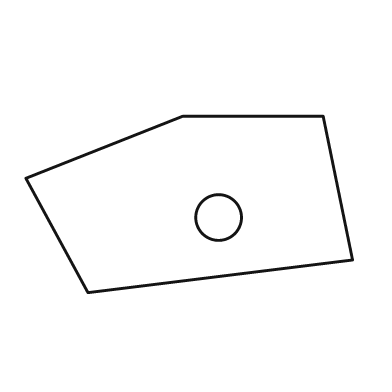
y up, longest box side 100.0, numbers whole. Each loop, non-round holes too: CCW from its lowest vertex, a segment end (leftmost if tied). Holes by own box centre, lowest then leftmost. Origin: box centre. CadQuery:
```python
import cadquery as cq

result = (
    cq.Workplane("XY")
    .moveTo(-31.0, -27.0)
    .lineTo(50.0, -17.0)
    .lineTo(41.0, 27.0)
    .lineTo(-2.0, 27.0)
    .lineTo(-50.0, 8.0)
    .close()
    .moveTo(9.0, -4.0)
    .circle(7.0)
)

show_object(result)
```